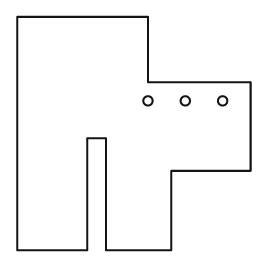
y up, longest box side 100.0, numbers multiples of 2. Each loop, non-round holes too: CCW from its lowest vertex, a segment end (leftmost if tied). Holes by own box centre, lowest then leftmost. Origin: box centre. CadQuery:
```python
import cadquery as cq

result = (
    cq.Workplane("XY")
    .moveTo(-50.0, -50.0)
    .lineTo(-20.0, -50.0)
    .lineTo(-20.0, -2.0)
    .lineTo(-12.0, -2.0)
    .lineTo(-12.0, -50.0)
    .lineTo(16.0, -50.0)
    .lineTo(16.0, -16.0)
    .lineTo(50.0, -16.0)
    .lineTo(50.0, 22.0)
    .lineTo(6.0, 22.0)
    .lineTo(6.0, 50.0)
    .lineTo(-50.0, 50.0)
    .close()
    .moveTo(6.0, 14.0)
    .circle(2.0)
    .moveTo(22.0, 14.0)
    .circle(2.0)
    .moveTo(38.0, 14.0)
    .circle(2.0)
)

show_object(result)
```